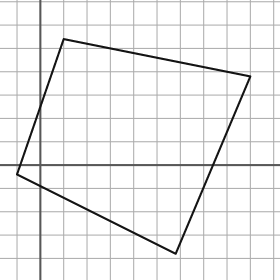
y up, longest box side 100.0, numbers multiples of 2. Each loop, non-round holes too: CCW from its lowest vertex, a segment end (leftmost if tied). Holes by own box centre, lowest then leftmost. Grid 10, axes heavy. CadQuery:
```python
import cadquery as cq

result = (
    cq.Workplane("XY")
    .moveTo(58.0, -38.0)
    .lineTo(90.0, 38.0)
    .lineTo(10.0, 54.0)
    .lineTo(-10.0, -4.0)
    .close()
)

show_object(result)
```